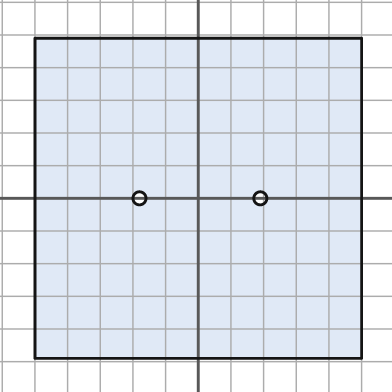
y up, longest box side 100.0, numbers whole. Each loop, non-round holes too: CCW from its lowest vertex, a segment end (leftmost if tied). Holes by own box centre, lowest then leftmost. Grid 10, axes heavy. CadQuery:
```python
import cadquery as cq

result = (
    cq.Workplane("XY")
    .moveTo(-50.0, -49.0)
    .lineTo(50.0, -49.0)
    .lineTo(50.0, 49.0)
    .lineTo(-50.0, 49.0)
    .close()
    .moveTo(-18.0, 0.0)
    .circle(2.0)
    .moveTo(19.0, 0.0)
    .circle(2.0)
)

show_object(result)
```